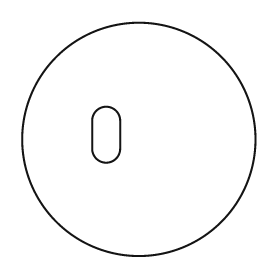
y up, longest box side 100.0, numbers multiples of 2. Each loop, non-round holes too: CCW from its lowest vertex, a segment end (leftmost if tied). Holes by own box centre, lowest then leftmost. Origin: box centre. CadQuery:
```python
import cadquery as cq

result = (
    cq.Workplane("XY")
    .moveTo(0.0, 0.0)
    .circle(50.0)
    .moveTo(-20.0, -4.0)
    .threePointArc((-14.0, -10.0), (-8.0, -4.0))
    .lineTo(-8.0, 8.0)
    .threePointArc((-14.0, 14.0), (-20.0, 8.0))
    .close()
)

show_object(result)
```